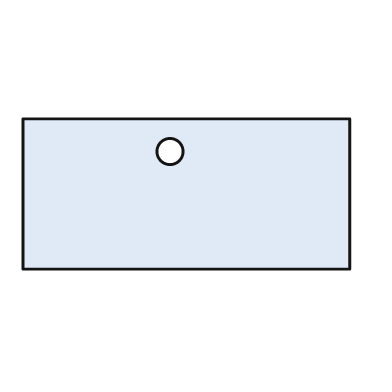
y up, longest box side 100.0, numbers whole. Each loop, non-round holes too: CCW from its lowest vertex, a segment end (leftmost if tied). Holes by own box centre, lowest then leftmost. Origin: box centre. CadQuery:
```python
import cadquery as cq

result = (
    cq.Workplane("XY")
    .moveTo(-50.0, -23.0)
    .lineTo(50.0, -23.0)
    .lineTo(50.0, 23.0)
    .lineTo(-50.0, 23.0)
    .close()
    .moveTo(-5.0, 13.0)
    .circle(4.0)
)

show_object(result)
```